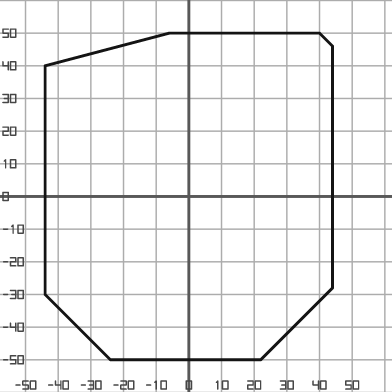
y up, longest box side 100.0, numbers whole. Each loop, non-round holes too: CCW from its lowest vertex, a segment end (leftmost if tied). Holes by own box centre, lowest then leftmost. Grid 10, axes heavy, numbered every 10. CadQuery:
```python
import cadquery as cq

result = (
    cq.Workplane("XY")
    .moveTo(-24.0, -50.0)
    .lineTo(22.0, -50.0)
    .lineTo(44.0, -28.0)
    .lineTo(44.0, 46.0)
    .lineTo(40.0, 50.0)
    .lineTo(-6.0, 50.0)
    .lineTo(-44.0, 40.0)
    .lineTo(-44.0, -30.0)
    .close()
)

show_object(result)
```